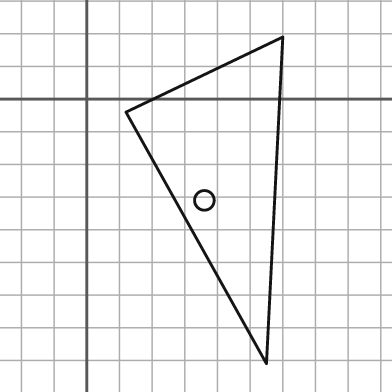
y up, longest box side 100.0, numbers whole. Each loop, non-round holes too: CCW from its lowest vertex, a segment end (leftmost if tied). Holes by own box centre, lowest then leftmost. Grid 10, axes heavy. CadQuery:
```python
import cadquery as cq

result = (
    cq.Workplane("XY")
    .moveTo(55.0, -81.0)
    .lineTo(60.0, 19.0)
    .lineTo(12.0, -4.0)
    .close()
    .moveTo(36.0, -31.0)
    .circle(3.0)
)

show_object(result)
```